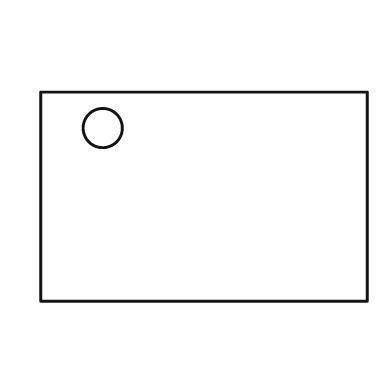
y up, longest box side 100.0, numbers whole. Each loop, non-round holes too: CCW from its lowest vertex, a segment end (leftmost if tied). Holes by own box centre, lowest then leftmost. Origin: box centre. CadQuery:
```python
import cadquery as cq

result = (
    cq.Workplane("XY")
    .moveTo(-50.0, -32.0)
    .lineTo(50.0, -32.0)
    .lineTo(50.0, 32.0)
    .lineTo(-50.0, 32.0)
    .close()
    .moveTo(-31.0, 21.0)
    .circle(6.0)
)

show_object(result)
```